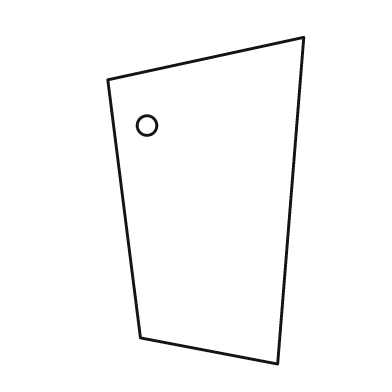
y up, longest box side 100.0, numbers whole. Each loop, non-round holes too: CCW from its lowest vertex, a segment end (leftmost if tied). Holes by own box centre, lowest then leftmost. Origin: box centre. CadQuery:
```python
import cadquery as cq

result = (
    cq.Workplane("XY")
    .moveTo(22.0, -50.0)
    .lineTo(30.0, 50.0)
    .lineTo(-30.0, 37.0)
    .lineTo(-20.0, -42.0)
    .close()
    .moveTo(-18.0, 23.0)
    .circle(3.0)
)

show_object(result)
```